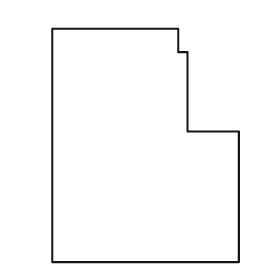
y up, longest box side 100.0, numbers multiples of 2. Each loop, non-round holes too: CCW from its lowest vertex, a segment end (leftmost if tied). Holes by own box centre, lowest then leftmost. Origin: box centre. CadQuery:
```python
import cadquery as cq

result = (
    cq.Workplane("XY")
    .moveTo(-40.0, -50.0)
    .lineTo(40.0, -50.0)
    .lineTo(40.0, 6.0)
    .lineTo(18.0, 6.0)
    .lineTo(18.0, 40.0)
    .lineTo(14.0, 40.0)
    .lineTo(14.0, 50.0)
    .lineTo(-40.0, 50.0)
    .close()
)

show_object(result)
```